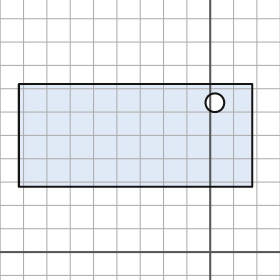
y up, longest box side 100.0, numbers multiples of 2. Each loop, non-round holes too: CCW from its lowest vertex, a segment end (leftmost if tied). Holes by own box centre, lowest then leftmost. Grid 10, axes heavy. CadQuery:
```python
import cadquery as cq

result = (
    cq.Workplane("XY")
    .moveTo(-82.0, 28.0)
    .lineTo(18.0, 28.0)
    .lineTo(18.0, 72.0)
    .lineTo(-82.0, 72.0)
    .close()
    .moveTo(2.0, 64.0)
    .circle(4.0)
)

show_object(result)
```